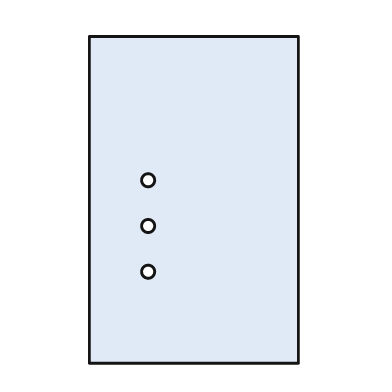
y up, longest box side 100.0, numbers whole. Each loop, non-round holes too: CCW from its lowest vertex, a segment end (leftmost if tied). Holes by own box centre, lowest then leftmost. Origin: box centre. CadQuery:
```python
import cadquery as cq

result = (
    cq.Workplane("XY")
    .moveTo(-32.0, -50.0)
    .lineTo(32.0, -50.0)
    .lineTo(32.0, 50.0)
    .lineTo(-32.0, 50.0)
    .close()
    .moveTo(-14.0, -22.0)
    .circle(2.0)
    .moveTo(-14.0, -8.0)
    .circle(2.0)
    .moveTo(-14.0, 6.0)
    .circle(2.0)
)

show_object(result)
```